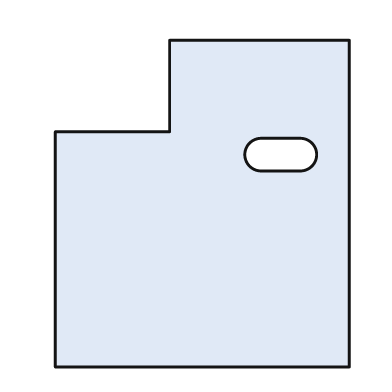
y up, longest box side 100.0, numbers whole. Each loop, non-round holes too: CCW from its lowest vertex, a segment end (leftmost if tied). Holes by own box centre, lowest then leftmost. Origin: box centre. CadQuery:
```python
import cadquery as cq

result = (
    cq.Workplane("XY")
    .moveTo(-45.0, -50.0)
    .lineTo(45.0, -50.0)
    .lineTo(45.0, 50.0)
    .lineTo(-10.0, 50.0)
    .lineTo(-10.0, 22.0)
    .lineTo(-45.0, 22.0)
    .close()
    .moveTo(18.0, 10.0)
    .lineTo(30.0, 10.0)
    .threePointArc((35.0, 15.0), (30.0, 20.0))
    .lineTo(18.0, 20.0)
    .threePointArc((13.0, 15.0), (18.0, 10.0))
    .close()
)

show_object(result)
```